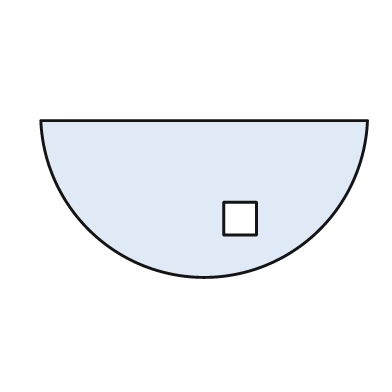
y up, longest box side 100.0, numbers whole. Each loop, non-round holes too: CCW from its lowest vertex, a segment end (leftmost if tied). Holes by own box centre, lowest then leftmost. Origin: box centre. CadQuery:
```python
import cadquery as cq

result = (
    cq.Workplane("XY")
    .moveTo(-50.0, 24.0)
    .threePointArc((0.0, -24.0), (50.0, 24.0))
    .close()
    .moveTo(6.0, -11.0)
    .lineTo(16.0, -11.0)
    .lineTo(16.0, -1.0)
    .lineTo(6.0, -1.0)
    .close()
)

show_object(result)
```